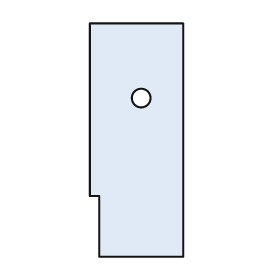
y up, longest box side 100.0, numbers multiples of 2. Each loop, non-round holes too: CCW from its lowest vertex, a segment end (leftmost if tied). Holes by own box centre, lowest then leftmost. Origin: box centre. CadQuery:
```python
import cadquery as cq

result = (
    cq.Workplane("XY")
    .moveTo(-16.0, -50.0)
    .lineTo(20.0, -50.0)
    .lineTo(20.0, 50.0)
    .lineTo(-20.0, 50.0)
    .lineTo(-20.0, -24.0)
    .lineTo(-16.0, -24.0)
    .close()
    .moveTo(2.0, 18.0)
    .circle(4.0)
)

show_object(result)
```